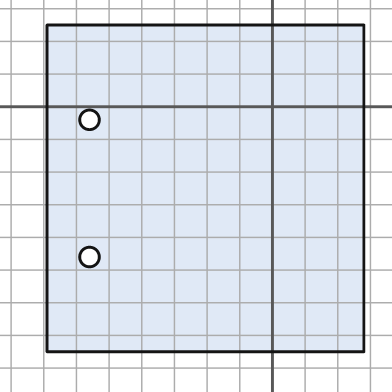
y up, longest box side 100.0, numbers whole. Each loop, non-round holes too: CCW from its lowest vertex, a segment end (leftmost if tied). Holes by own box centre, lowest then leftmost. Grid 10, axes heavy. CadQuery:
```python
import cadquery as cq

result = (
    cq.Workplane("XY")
    .moveTo(-69.0, -75.0)
    .lineTo(28.0, -75.0)
    .lineTo(28.0, 25.0)
    .lineTo(-69.0, 25.0)
    .close()
    .moveTo(-56.0, -46.0)
    .circle(3.0)
    .moveTo(-56.0, -4.0)
    .circle(3.0)
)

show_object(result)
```